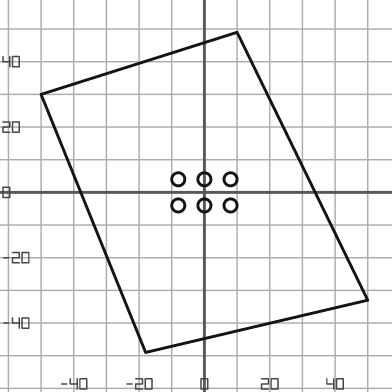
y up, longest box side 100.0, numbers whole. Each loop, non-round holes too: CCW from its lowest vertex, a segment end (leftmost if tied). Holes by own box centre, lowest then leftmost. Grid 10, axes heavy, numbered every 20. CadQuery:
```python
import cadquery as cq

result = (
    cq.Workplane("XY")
    .moveTo(-18.0, -49.0)
    .lineTo(50.0, -33.0)
    .lineTo(10.0, 49.0)
    .lineTo(-50.0, 30.0)
    .close()
    .moveTo(-8.0, -4.0)
    .circle(2.0)
    .moveTo(0.0, -4.0)
    .circle(2.0)
    .moveTo(8.0, -4.0)
    .circle(2.0)
    .moveTo(-8.0, 4.0)
    .circle(2.0)
    .moveTo(0.0, 4.0)
    .circle(2.0)
    .moveTo(8.0, 4.0)
    .circle(2.0)
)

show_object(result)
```